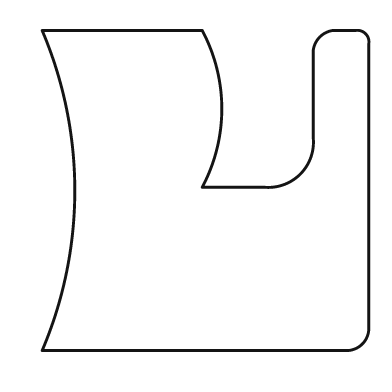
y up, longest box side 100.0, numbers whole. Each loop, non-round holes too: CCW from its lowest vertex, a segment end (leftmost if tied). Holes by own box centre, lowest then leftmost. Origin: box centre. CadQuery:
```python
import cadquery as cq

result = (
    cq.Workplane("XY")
    .moveTo(-50.0, -49.0)
    .lineTo(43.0, -49.0)
    .threePointArc((48.0, -47.0), (50.0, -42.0))
    .lineTo(50.0, 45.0)
    .threePointArc((49.0, 48.0), (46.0, 49.0))
    .lineTo(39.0, 49.0)
    .threePointArc((35.0, 47.0), (33.0, 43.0))
    .lineTo(33.0, 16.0)
    .threePointArc((29.0, 5.0), (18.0, 1.0))
    .lineTo(-1.0, 1.0)
    .threePointArc((5.0, 25.0), (-1.0, 49.0))
    .lineTo(-50.0, 49.0)
    .threePointArc((-40.0, 0.0), (-50.0, -49.0))
    .close()
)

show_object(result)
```